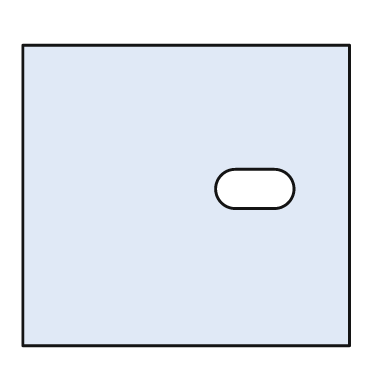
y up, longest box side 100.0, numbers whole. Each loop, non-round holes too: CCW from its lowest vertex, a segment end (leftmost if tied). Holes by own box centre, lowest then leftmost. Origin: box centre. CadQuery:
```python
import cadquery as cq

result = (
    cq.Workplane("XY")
    .moveTo(-50.0, -46.0)
    .lineTo(50.0, -46.0)
    .lineTo(50.0, 46.0)
    .lineTo(-50.0, 46.0)
    .close()
    .moveTo(15.0, -4.0)
    .lineTo(27.0, -4.0)
    .threePointArc((33.0, 2.0), (27.0, 8.0))
    .lineTo(15.0, 8.0)
    .threePointArc((9.0, 2.0), (15.0, -4.0))
    .close()
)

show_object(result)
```